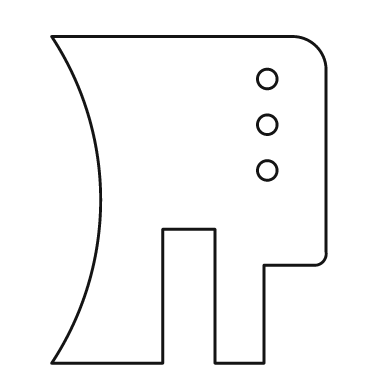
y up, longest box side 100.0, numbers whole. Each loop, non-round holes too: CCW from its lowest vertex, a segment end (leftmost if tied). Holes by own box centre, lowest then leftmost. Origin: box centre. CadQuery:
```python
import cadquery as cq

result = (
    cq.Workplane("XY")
    .moveTo(-42.0, -50.0)
    .lineTo(-8.0, -50.0)
    .lineTo(-8.0, -9.0)
    .lineTo(8.0, -9.0)
    .lineTo(8.0, -50.0)
    .lineTo(23.0, -50.0)
    .lineTo(23.0, -20.0)
    .lineTo(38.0, -20.0)
    .threePointArc((41.0, -19.0), (42.0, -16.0))
    .lineTo(42.0, 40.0)
    .threePointArc((39.0, 47.0), (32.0, 50.0))
    .lineTo(-42.0, 50.0)
    .threePointArc((-27.0, 0.0), (-42.0, -50.0))
    .close()
    .moveTo(24.0, 9.0)
    .circle(3.0)
    .moveTo(24.0, 23.0)
    .circle(3.0)
    .moveTo(24.0, 37.0)
    .circle(3.0)
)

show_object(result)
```